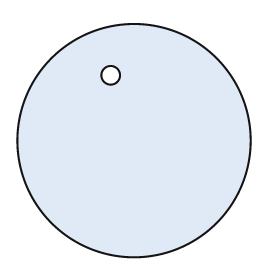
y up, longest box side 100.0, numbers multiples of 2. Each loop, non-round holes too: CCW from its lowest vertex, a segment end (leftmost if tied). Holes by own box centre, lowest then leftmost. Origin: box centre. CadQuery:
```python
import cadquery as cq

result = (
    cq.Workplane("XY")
    .moveTo(0.0, 0.0)
    .circle(50.0)
    .moveTo(-10.0, 28.0)
    .circle(4.0)
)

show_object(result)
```